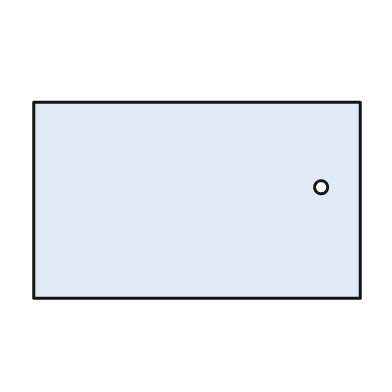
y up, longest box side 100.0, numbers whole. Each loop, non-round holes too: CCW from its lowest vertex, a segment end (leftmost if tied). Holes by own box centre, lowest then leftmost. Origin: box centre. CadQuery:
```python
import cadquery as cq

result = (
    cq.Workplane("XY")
    .moveTo(-50.0, -30.0)
    .lineTo(50.0, -30.0)
    .lineTo(50.0, 30.0)
    .lineTo(-50.0, 30.0)
    .close()
    .moveTo(38.0, 4.0)
    .circle(2.0)
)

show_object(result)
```